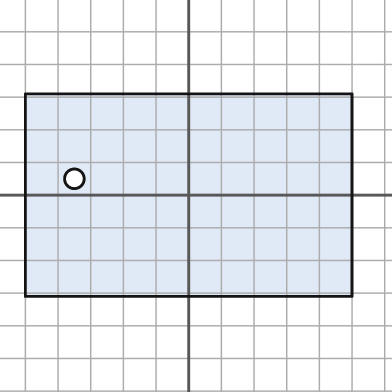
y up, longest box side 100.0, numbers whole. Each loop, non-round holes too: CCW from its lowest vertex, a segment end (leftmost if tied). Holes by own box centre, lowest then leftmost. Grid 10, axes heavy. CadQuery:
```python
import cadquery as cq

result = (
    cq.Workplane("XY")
    .moveTo(-50.0, -31.0)
    .lineTo(50.0, -31.0)
    .lineTo(50.0, 31.0)
    .lineTo(-50.0, 31.0)
    .close()
    .moveTo(-35.0, 5.0)
    .circle(3.0)
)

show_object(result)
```